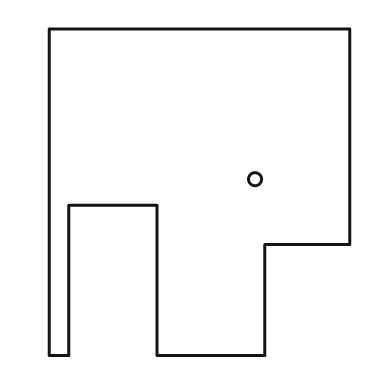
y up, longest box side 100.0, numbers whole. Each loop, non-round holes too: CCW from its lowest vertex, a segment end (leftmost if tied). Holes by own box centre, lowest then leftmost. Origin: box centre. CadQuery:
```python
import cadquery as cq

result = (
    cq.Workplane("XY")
    .moveTo(-46.0, -50.0)
    .lineTo(-40.0, -50.0)
    .lineTo(-40.0, -4.0)
    .lineTo(-13.0, -4.0)
    .lineTo(-13.0, -50.0)
    .lineTo(20.0, -50.0)
    .lineTo(20.0, -16.0)
    .lineTo(46.0, -16.0)
    .lineTo(46.0, 50.0)
    .lineTo(-46.0, 50.0)
    .close()
    .moveTo(17.0, 4.0)
    .circle(2.0)
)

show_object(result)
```